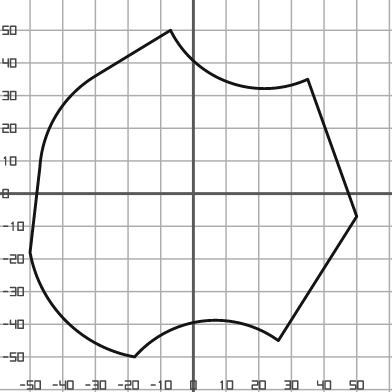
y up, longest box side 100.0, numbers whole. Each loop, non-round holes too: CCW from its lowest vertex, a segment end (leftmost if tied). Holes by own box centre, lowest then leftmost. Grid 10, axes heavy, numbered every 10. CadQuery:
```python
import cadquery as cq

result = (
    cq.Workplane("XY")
    .moveTo(-18.0, -50.0)
    .threePointArc((3.0, -39.0), (26.0, -45.0))
    .lineTo(50.0, -7.0)
    .lineTo(35.0, 35.0)
    .threePointArc((11.0, 34.0), (-7.0, 50.0))
    .lineTo(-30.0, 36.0)
    .threePointArc((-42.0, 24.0), (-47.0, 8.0))
    .lineTo(-50.0, -18.0)
    .threePointArc((-39.0, -39.0), (-18.0, -50.0))
    .close()
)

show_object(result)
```